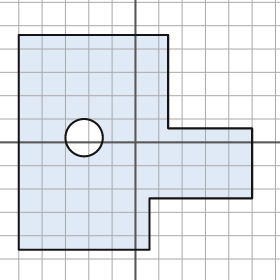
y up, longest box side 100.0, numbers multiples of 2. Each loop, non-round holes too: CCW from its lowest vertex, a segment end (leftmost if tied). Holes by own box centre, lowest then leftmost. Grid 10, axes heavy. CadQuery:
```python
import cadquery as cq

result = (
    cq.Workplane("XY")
    .moveTo(-50.0, -46.0)
    .lineTo(6.0, -46.0)
    .lineTo(6.0, -24.0)
    .lineTo(50.0, -24.0)
    .lineTo(50.0, 6.0)
    .lineTo(14.0, 6.0)
    .lineTo(14.0, 46.0)
    .lineTo(-50.0, 46.0)
    .close()
    .moveTo(-22.0, 2.0)
    .circle(8.0)
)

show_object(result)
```